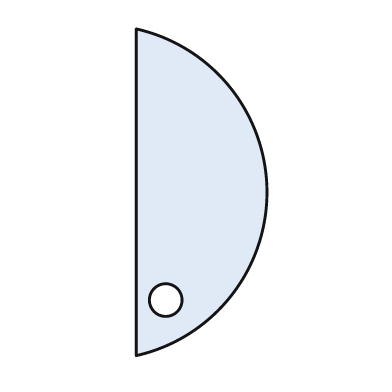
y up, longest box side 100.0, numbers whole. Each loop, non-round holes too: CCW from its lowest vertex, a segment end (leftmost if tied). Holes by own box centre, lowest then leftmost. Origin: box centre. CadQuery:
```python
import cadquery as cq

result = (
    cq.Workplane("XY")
    .moveTo(-20.0, -50.0)
    .threePointArc((20.0, 0.0), (-20.0, 50.0))
    .close()
    .moveTo(-11.0, -33.0)
    .circle(5.0)
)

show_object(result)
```